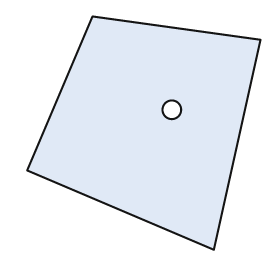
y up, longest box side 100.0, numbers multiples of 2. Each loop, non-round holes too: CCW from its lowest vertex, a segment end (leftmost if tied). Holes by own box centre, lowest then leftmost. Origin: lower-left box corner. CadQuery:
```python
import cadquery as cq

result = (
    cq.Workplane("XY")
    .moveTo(80.0, 0.0)
    .lineTo(100.0, 90.0)
    .lineTo(28.0, 100.0)
    .lineTo(0.0, 34.0)
    .close()
    .moveTo(62.0, 60.0)
    .circle(4.0)
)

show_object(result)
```